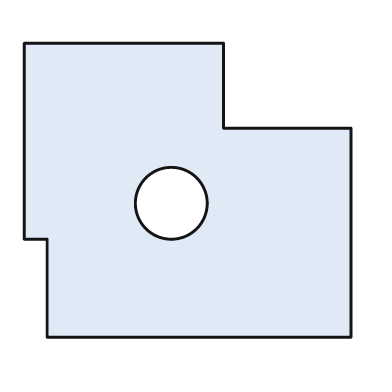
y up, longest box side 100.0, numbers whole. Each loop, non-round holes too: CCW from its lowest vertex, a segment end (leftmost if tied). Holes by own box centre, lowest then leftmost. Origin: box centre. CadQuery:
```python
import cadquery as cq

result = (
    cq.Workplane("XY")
    .moveTo(-43.0, -45.0)
    .lineTo(50.0, -45.0)
    .lineTo(50.0, 19.0)
    .lineTo(11.0, 19.0)
    .lineTo(11.0, 45.0)
    .lineTo(-50.0, 45.0)
    .lineTo(-50.0, -15.0)
    .lineTo(-43.0, -15.0)
    .close()
    .moveTo(-5.0, -4.0)
    .circle(11.0)
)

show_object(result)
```